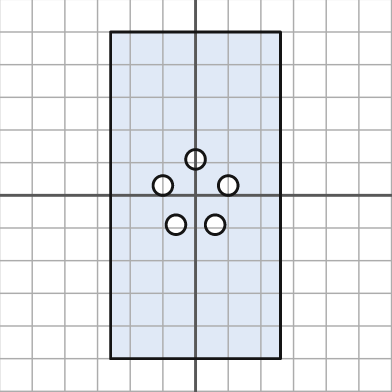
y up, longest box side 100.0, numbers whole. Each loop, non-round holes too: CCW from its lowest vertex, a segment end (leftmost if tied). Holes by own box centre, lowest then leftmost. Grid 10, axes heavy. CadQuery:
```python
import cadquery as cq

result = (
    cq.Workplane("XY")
    .moveTo(-26.0, -50.0)
    .lineTo(26.0, -50.0)
    .lineTo(26.0, 50.0)
    .lineTo(-26.0, 50.0)
    .close()
    .moveTo(-6.0, -9.0)
    .circle(3.0)
    .moveTo(6.0, -9.0)
    .circle(3.0)
    .moveTo(-10.0, 3.0)
    .circle(3.0)
    .moveTo(10.0, 3.0)
    .circle(3.0)
    .moveTo(0.0, 11.0)
    .circle(3.0)
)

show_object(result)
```